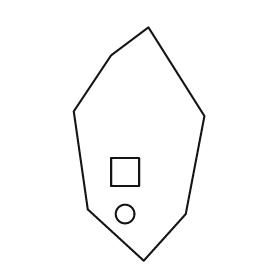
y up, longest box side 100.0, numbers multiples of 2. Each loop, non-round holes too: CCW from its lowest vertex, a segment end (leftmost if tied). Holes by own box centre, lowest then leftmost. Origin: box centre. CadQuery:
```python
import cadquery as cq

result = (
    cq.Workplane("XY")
    .moveTo(2.0, -50.0)
    .lineTo(20.0, -30.0)
    .lineTo(28.0, 12.0)
    .lineTo(4.0, 50.0)
    .lineTo(-12.0, 38.0)
    .lineTo(-28.0, 14.0)
    .lineTo(-22.0, -28.0)
    .close()
    .moveTo(-6.0, -30.0)
    .circle(4.0)
    .moveTo(-12.0, -18.0)
    .lineTo(0.0, -18.0)
    .lineTo(0.0, -6.0)
    .lineTo(-12.0, -6.0)
    .close()
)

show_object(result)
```